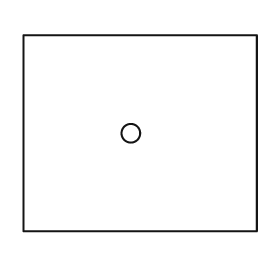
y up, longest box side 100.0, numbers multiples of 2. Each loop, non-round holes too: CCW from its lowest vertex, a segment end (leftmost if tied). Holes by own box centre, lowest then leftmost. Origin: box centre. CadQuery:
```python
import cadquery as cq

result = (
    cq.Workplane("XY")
    .moveTo(-50.0, -42.0)
    .lineTo(50.0, -42.0)
    .lineTo(50.0, 42.0)
    .lineTo(-50.0, 42.0)
    .close()
    .moveTo(-4.0, 0.0)
    .circle(4.0)
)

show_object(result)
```